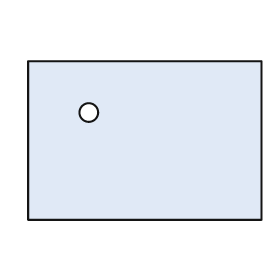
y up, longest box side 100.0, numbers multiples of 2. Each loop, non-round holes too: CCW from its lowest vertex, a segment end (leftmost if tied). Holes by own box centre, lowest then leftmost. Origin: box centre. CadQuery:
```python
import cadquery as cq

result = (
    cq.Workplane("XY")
    .moveTo(-50.0, -34.0)
    .lineTo(50.0, -34.0)
    .lineTo(50.0, 34.0)
    .lineTo(-50.0, 34.0)
    .close()
    .moveTo(-24.0, 12.0)
    .circle(4.0)
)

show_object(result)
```